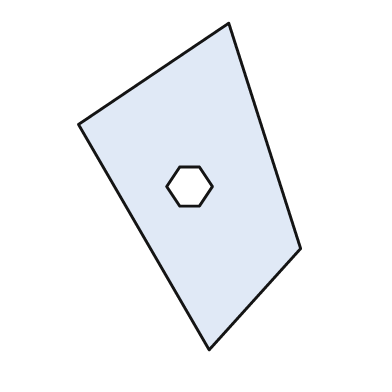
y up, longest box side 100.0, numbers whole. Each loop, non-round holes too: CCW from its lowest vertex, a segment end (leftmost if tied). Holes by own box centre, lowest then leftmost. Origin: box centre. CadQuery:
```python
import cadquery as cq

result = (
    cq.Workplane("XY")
    .moveTo(6.0, -50.0)
    .lineTo(34.0, -19.0)
    .lineTo(12.0, 50.0)
    .lineTo(-34.0, 19.0)
    .close()
    .moveTo(-3.0, -6.0)
    .lineTo(3.0, -6.0)
    .lineTo(7.0, 0.0)
    .lineTo(3.0, 6.0)
    .lineTo(-3.0, 6.0)
    .lineTo(-7.0, 0.0)
    .close()
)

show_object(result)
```